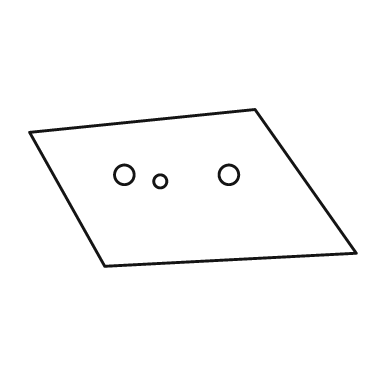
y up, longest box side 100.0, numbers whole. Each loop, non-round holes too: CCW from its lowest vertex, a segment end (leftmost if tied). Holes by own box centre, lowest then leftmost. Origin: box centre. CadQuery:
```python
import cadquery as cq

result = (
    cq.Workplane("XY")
    .moveTo(-27.0, -24.0)
    .lineTo(50.0, -20.0)
    .lineTo(19.0, 24.0)
    .lineTo(-50.0, 17.0)
    .close()
    .moveTo(-10.0, 2.0)
    .circle(2.0)
    .moveTo(-21.0, 4.0)
    .circle(3.0)
    .moveTo(11.0, 4.0)
    .circle(3.0)
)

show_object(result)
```